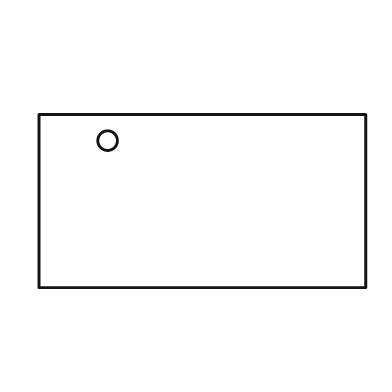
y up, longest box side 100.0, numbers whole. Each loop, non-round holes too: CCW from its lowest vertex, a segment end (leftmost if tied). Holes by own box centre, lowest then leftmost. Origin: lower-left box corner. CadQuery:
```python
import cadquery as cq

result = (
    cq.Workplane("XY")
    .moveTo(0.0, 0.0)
    .lineTo(100.0, 0.0)
    .lineTo(100.0, 53.0)
    .lineTo(0.0, 53.0)
    .close()
    .moveTo(21.0, 45.0)
    .circle(3.0)
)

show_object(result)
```